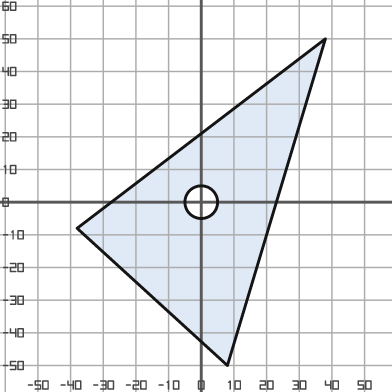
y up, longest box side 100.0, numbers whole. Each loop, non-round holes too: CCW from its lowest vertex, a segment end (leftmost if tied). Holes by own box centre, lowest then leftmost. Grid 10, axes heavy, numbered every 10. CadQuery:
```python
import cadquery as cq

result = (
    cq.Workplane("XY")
    .moveTo(8.0, -50.0)
    .lineTo(38.0, 50.0)
    .lineTo(-38.0, -8.0)
    .close()
    .moveTo(0.0, 0.0)
    .circle(5.0)
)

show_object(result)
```